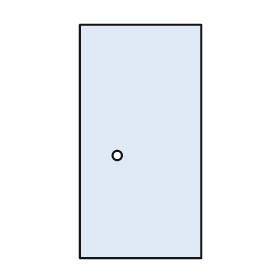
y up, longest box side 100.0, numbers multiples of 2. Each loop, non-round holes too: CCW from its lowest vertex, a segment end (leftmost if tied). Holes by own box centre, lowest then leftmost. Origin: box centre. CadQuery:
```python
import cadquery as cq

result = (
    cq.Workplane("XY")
    .moveTo(-26.0, -50.0)
    .lineTo(26.0, -50.0)
    .lineTo(26.0, 50.0)
    .lineTo(-26.0, 50.0)
    .close()
    .moveTo(-10.0, -6.0)
    .circle(2.0)
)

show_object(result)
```